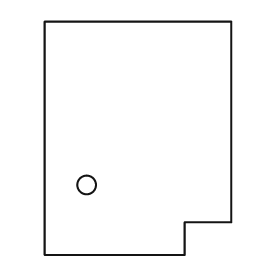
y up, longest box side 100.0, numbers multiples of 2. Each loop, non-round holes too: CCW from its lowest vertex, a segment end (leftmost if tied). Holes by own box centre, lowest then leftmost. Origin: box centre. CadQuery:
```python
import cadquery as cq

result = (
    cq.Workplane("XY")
    .moveTo(-40.0, -50.0)
    .lineTo(20.0, -50.0)
    .lineTo(20.0, -36.0)
    .lineTo(40.0, -36.0)
    .lineTo(40.0, 50.0)
    .lineTo(-40.0, 50.0)
    .close()
    .moveTo(-22.0, -20.0)
    .circle(4.0)
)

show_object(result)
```